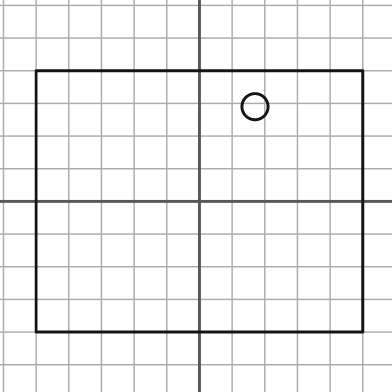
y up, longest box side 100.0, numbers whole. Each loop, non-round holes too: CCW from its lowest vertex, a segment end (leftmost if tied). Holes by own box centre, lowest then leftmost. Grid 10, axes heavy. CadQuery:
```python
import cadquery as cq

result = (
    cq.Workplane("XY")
    .moveTo(-50.0, -40.0)
    .lineTo(50.0, -40.0)
    .lineTo(50.0, 40.0)
    .lineTo(-50.0, 40.0)
    .close()
    .moveTo(17.0, 29.0)
    .circle(4.0)
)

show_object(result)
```